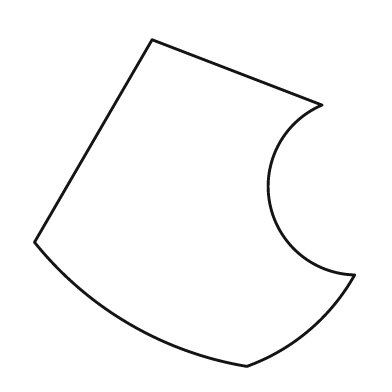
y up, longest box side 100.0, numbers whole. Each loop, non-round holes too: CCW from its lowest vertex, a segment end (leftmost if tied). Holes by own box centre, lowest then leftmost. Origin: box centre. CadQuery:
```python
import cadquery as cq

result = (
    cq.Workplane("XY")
    .moveTo(16.0, -50.0)
    .threePointArc((35.0, -39.0), (49.0, -22.0))
    .threePointArc((23.0, 0.0), (39.0, 30.0))
    .lineTo(-13.0, 50.0)
    .lineTo(-49.0, -12.0)
    .threePointArc((-20.0, -37.0), (16.0, -50.0))
    .close()
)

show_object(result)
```